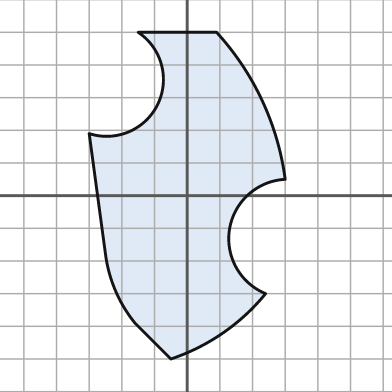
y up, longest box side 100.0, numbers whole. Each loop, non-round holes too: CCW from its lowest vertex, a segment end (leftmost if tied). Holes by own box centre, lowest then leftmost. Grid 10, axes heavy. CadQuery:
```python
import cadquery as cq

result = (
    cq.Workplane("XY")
    .moveTo(-5.0, -50.0)
    .threePointArc((11.0, -42.0), (24.0, -30.0))
    .threePointArc((13.0, -10.0), (30.0, 5.0))
    .threePointArc((23.0, 29.0), (9.0, 50.0))
    .lineTo(-15.0, 50.0)
    .threePointArc((-9.0, 28.0), (-30.0, 19.0))
    .lineTo(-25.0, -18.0)
    .threePointArc((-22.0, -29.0), (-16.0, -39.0))
    .close()
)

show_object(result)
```